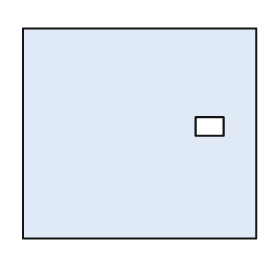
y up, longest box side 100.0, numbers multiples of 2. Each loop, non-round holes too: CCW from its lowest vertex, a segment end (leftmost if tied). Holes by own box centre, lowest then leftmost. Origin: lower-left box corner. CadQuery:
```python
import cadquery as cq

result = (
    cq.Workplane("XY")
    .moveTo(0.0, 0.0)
    .lineTo(100.0, 0.0)
    .lineTo(100.0, 90.0)
    .lineTo(0.0, 90.0)
    .close()
    .moveTo(74.0, 44.0)
    .lineTo(86.0, 44.0)
    .lineTo(86.0, 52.0)
    .lineTo(74.0, 52.0)
    .close()
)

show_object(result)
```